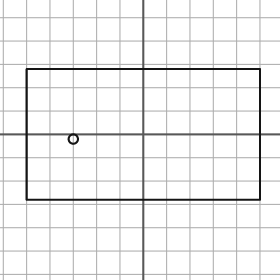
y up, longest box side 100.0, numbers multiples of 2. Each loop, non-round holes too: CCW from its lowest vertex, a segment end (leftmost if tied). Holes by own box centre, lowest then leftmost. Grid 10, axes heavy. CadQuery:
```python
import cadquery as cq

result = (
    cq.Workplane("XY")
    .moveTo(-50.0, -28.0)
    .lineTo(50.0, -28.0)
    .lineTo(50.0, 28.0)
    .lineTo(-50.0, 28.0)
    .close()
    .moveTo(-30.0, -2.0)
    .circle(2.0)
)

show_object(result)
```